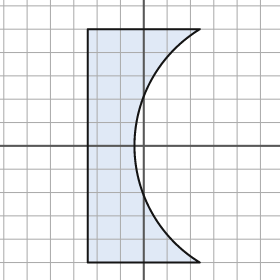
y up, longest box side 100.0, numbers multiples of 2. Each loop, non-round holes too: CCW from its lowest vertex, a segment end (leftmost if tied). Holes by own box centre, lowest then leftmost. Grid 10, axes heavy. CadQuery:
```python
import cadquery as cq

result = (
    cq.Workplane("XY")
    .moveTo(-24.0, -50.0)
    .lineTo(24.0, -50.0)
    .threePointArc((-4.0, 0.0), (24.0, 50.0))
    .lineTo(-24.0, 50.0)
    .close()
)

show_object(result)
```